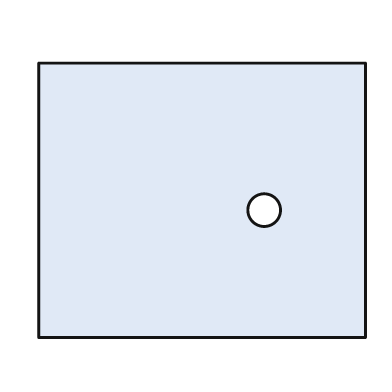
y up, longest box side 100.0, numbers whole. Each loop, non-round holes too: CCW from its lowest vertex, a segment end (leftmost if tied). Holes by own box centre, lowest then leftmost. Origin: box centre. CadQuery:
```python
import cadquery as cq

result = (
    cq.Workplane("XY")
    .moveTo(-50.0, -42.0)
    .lineTo(50.0, -42.0)
    .lineTo(50.0, 42.0)
    .lineTo(-50.0, 42.0)
    .close()
    .moveTo(19.0, -3.0)
    .circle(5.0)
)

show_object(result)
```